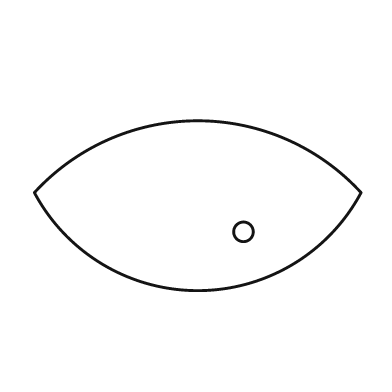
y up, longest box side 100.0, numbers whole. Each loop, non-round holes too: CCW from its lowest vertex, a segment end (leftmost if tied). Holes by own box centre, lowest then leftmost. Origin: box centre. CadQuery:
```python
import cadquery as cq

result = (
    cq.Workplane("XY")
    .moveTo(-50.0, 4.0)
    .threePointArc((0.0, -26.0), (50.0, 4.0))
    .threePointArc((0.0, 26.0), (-50.0, 4.0))
    .close()
    .moveTo(14.0, -8.0)
    .circle(3.0)
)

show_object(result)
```